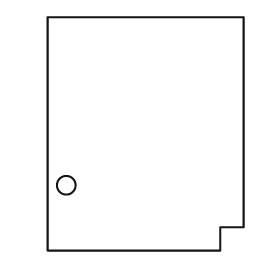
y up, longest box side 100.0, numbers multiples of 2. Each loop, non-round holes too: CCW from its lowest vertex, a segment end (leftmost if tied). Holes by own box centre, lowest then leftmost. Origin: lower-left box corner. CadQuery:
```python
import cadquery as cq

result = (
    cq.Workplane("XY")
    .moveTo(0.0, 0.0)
    .lineTo(74.0, 0.0)
    .lineTo(74.0, 10.0)
    .lineTo(84.0, 10.0)
    .lineTo(84.0, 100.0)
    .lineTo(0.0, 100.0)
    .close()
    .moveTo(8.0, 28.0)
    .circle(4.0)
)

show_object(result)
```